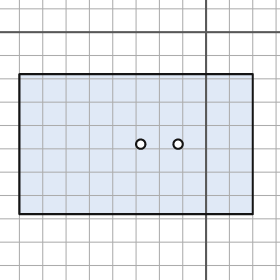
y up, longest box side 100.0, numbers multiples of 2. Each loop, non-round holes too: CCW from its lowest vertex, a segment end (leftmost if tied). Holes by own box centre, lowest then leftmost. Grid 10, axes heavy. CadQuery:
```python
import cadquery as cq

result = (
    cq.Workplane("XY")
    .moveTo(-80.0, -78.0)
    .lineTo(20.0, -78.0)
    .lineTo(20.0, -18.0)
    .lineTo(-80.0, -18.0)
    .close()
    .moveTo(-28.0, -48.0)
    .circle(2.0)
    .moveTo(-12.0, -48.0)
    .circle(2.0)
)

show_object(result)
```